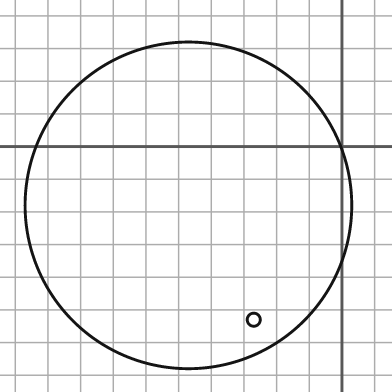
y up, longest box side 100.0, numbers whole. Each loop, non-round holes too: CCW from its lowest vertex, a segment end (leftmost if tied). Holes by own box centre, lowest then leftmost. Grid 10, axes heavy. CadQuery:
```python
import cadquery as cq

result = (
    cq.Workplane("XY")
    .moveTo(-47.0, -18.0)
    .circle(50.0)
    .moveTo(-27.0, -53.0)
    .circle(2.0)
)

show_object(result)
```